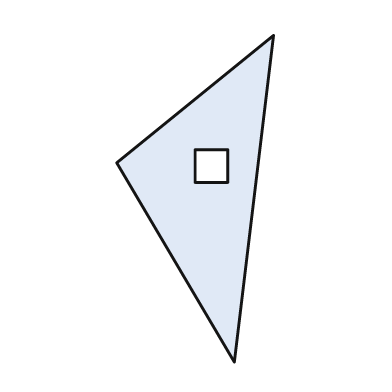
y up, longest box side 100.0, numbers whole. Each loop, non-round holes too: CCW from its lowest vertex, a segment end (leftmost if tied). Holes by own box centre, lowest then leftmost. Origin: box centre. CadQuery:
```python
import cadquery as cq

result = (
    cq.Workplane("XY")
    .moveTo(12.0, -50.0)
    .lineTo(24.0, 50.0)
    .lineTo(-24.0, 11.0)
    .close()
    .moveTo(0.0, 5.0)
    .lineTo(10.0, 5.0)
    .lineTo(10.0, 15.0)
    .lineTo(0.0, 15.0)
    .close()
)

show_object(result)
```